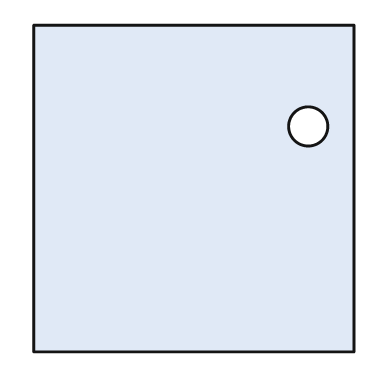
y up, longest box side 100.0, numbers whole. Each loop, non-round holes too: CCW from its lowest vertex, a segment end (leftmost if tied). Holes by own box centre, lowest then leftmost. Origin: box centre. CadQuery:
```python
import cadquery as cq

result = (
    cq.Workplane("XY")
    .moveTo(-49.0, -50.0)
    .lineTo(49.0, -50.0)
    .lineTo(49.0, 50.0)
    .lineTo(-49.0, 50.0)
    .close()
    .moveTo(35.0, 19.0)
    .circle(6.0)
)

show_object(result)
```